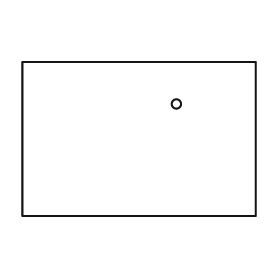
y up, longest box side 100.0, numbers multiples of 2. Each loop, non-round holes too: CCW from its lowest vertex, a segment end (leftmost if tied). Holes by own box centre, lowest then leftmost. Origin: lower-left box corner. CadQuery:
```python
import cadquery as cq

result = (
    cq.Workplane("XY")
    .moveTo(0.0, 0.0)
    .lineTo(100.0, 0.0)
    .lineTo(100.0, 66.0)
    .lineTo(0.0, 66.0)
    .close()
    .moveTo(66.0, 48.0)
    .circle(2.0)
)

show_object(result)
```